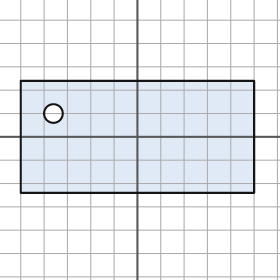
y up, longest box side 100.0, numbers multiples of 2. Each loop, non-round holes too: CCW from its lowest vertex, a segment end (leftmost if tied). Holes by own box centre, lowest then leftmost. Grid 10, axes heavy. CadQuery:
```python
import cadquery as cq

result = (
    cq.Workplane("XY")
    .moveTo(-50.0, -24.0)
    .lineTo(50.0, -24.0)
    .lineTo(50.0, 24.0)
    .lineTo(-50.0, 24.0)
    .close()
    .moveTo(-36.0, 10.0)
    .circle(4.0)
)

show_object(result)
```